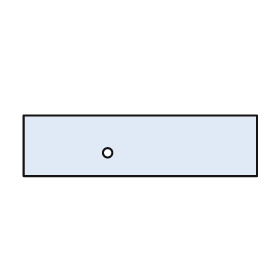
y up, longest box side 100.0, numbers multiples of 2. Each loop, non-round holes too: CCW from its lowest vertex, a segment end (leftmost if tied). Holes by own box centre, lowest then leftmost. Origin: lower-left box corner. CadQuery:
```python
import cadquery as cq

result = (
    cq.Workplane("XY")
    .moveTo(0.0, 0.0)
    .lineTo(100.0, 0.0)
    .lineTo(100.0, 26.0)
    .lineTo(0.0, 26.0)
    .close()
    .moveTo(36.0, 10.0)
    .circle(2.0)
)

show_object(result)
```